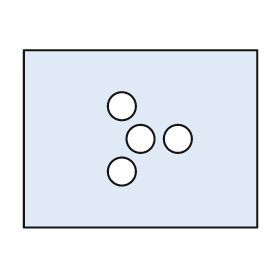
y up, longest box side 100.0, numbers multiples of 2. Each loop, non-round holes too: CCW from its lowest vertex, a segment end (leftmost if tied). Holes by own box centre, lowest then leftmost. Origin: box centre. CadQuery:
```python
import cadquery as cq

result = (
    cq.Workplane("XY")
    .moveTo(-50.0, -38.0)
    .lineTo(50.0, -38.0)
    .lineTo(50.0, 38.0)
    .lineTo(-50.0, 38.0)
    .close()
    .moveTo(-8.0, -14.0)
    .circle(6.0)
    .moveTo(0.0, 0.0)
    .circle(6.0)
    .moveTo(16.0, 0.0)
    .circle(6.0)
    .moveTo(-8.0, 14.0)
    .circle(6.0)
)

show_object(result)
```